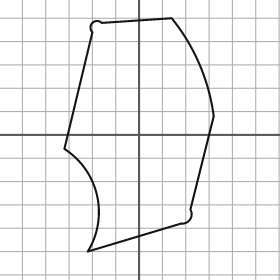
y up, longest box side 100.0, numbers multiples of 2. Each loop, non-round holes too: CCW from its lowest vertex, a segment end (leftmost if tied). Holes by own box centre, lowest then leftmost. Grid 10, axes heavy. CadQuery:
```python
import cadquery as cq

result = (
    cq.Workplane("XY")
    .moveTo(-22.0, -50.0)
    .lineTo(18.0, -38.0)
    .threePointArc((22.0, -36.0), (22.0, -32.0))
    .lineTo(32.0, 8.0)
    .threePointArc((26.0, 30.0), (14.0, 50.0))
    .lineTo(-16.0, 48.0)
    .threePointArc((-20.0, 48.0), (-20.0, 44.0))
    .lineTo(-32.0, -6.0)
    .threePointArc((-18.0, -26.0), (-22.0, -50.0))
    .close()
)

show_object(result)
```